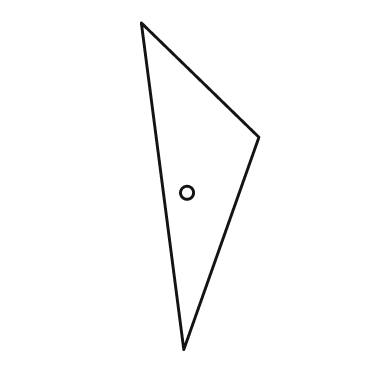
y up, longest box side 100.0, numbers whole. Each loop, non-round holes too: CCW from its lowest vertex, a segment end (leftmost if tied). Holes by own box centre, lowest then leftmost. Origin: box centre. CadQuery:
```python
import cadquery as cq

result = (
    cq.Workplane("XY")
    .moveTo(-5.0, -50.0)
    .lineTo(18.0, 15.0)
    .lineTo(-18.0, 50.0)
    .close()
    .moveTo(-4.0, -2.0)
    .circle(2.0)
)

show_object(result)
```